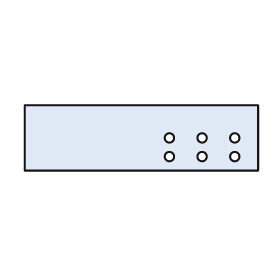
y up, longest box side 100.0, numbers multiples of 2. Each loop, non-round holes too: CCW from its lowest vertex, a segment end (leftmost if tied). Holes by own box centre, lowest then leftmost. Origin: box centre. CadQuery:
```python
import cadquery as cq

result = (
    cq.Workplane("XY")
    .moveTo(-50.0, -14.0)
    .lineTo(50.0, -14.0)
    .lineTo(50.0, 14.0)
    .lineTo(-50.0, 14.0)
    .close()
    .moveTo(12.0, -8.0)
    .circle(2.0)
    .moveTo(26.0, -8.0)
    .circle(2.0)
    .moveTo(40.0, -8.0)
    .circle(2.0)
    .moveTo(12.0, 0.0)
    .circle(2.0)
    .moveTo(26.0, 0.0)
    .circle(2.0)
    .moveTo(40.0, 0.0)
    .circle(2.0)
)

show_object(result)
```